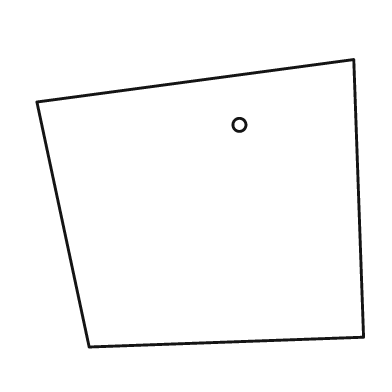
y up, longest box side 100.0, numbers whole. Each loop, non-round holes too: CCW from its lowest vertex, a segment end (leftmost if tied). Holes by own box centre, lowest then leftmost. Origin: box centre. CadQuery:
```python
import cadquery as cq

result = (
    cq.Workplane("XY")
    .moveTo(-34.0, -44.0)
    .lineTo(50.0, -41.0)
    .lineTo(47.0, 44.0)
    .lineTo(-50.0, 31.0)
    .close()
    .moveTo(12.0, 24.0)
    .circle(2.0)
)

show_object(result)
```